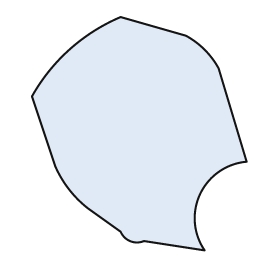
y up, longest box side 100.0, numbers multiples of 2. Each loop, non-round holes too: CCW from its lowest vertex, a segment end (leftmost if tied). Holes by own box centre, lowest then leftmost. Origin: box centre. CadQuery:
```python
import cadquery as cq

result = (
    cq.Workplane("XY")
    .moveTo(28.0, -50.0)
    .threePointArc((26.0, -26.0), (46.0, -12.0))
    .lineTo(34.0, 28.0)
    .threePointArc((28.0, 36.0), (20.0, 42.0))
    .lineTo(-8.0, 50.0)
    .threePointArc((-30.0, 36.0), (-46.0, 16.0))
    .lineTo(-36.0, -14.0)
    .threePointArc((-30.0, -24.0), (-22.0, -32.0))
    .lineTo(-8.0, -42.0)
    .threePointArc((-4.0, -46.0), (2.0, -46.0))
    .close()
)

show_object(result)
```